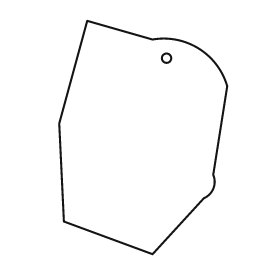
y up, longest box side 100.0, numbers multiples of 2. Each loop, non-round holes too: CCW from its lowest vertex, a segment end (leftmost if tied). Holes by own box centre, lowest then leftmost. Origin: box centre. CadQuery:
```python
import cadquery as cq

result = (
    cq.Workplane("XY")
    .moveTo(4.0, -50.0)
    .lineTo(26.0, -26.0)
    .threePointArc((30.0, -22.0), (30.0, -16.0))
    .lineTo(36.0, 22.0)
    .threePointArc((24.0, 38.0), (4.0, 42.0))
    .lineTo(-24.0, 50.0)
    .lineTo(-36.0, 6.0)
    .lineTo(-34.0, -36.0)
    .close()
    .moveTo(10.0, 34.0)
    .circle(2.0)
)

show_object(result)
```